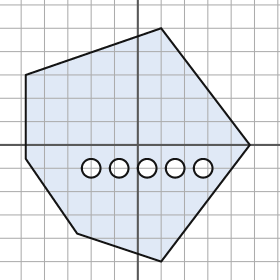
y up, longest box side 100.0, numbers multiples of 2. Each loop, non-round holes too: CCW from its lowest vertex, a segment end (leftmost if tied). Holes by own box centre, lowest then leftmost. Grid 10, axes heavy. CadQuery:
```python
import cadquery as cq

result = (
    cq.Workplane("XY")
    .moveTo(10.0, -50.0)
    .lineTo(48.0, 0.0)
    .lineTo(10.0, 50.0)
    .lineTo(-48.0, 30.0)
    .lineTo(-48.0, -6.0)
    .lineTo(-26.0, -38.0)
    .close()
    .moveTo(-20.0, -10.0)
    .circle(4.0)
    .moveTo(-8.0, -10.0)
    .circle(4.0)
    .moveTo(4.0, -10.0)
    .circle(4.0)
    .moveTo(16.0, -10.0)
    .circle(4.0)
    .moveTo(28.0, -10.0)
    .circle(4.0)
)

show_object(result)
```